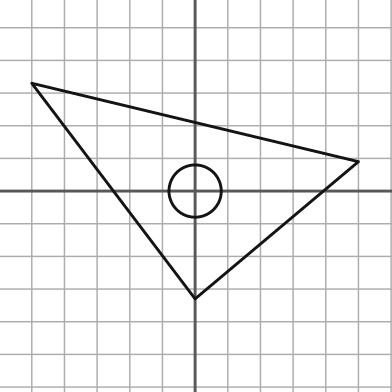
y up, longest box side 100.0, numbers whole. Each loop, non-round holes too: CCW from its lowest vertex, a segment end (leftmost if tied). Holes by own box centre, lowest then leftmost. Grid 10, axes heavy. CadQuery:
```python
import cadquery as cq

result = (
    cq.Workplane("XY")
    .moveTo(0.0, -33.0)
    .lineTo(50.0, 9.0)
    .lineTo(-50.0, 33.0)
    .close()
    .moveTo(0.0, 0.0)
    .circle(8.0)
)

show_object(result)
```